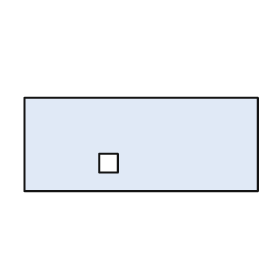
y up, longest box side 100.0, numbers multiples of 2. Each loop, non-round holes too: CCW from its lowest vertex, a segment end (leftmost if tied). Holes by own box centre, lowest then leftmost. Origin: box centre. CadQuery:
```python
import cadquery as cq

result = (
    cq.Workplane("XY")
    .moveTo(-50.0, -20.0)
    .lineTo(50.0, -20.0)
    .lineTo(50.0, 20.0)
    .lineTo(-50.0, 20.0)
    .close()
    .moveTo(-18.0, -12.0)
    .lineTo(-10.0, -12.0)
    .lineTo(-10.0, -4.0)
    .lineTo(-18.0, -4.0)
    .close()
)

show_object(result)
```